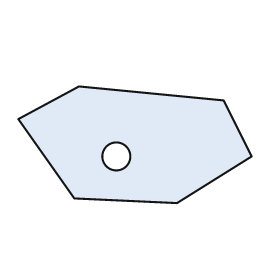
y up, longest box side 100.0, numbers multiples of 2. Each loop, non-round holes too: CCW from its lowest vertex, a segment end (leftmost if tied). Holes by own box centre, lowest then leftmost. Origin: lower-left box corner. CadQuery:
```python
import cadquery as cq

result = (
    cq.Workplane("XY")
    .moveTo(68.0, 0.0)
    .lineTo(100.0, 20.0)
    .lineTo(88.0, 44.0)
    .lineTo(26.0, 50.0)
    .lineTo(0.0, 36.0)
    .lineTo(24.0, 2.0)
    .close()
    .moveTo(42.0, 20.0)
    .circle(6.0)
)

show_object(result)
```